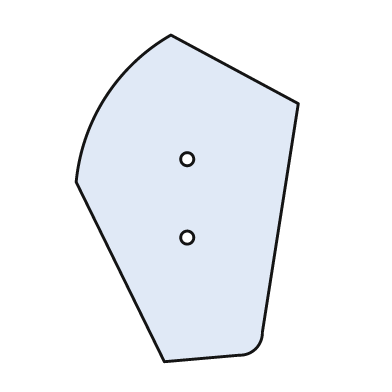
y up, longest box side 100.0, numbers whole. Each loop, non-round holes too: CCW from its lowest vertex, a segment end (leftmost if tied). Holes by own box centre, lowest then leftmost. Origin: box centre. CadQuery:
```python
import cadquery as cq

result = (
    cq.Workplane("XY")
    .moveTo(-7.0, -50.0)
    .lineTo(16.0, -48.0)
    .threePointArc((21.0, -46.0), (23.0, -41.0))
    .lineTo(34.0, 29.0)
    .lineTo(-5.0, 50.0)
    .threePointArc((-25.0, 31.0), (-34.0, 5.0))
    .close()
    .moveTo(0.0, -12.0)
    .circle(2.0)
    .moveTo(0.0, 12.0)
    .circle(2.0)
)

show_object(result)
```